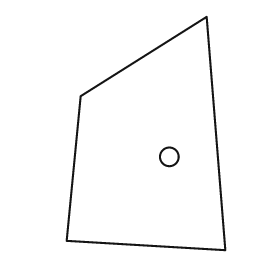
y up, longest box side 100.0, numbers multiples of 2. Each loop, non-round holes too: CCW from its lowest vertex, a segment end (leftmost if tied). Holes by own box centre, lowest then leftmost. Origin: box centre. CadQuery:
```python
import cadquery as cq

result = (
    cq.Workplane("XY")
    .moveTo(34.0, -50.0)
    .lineTo(26.0, 50.0)
    .lineTo(-28.0, 16.0)
    .lineTo(-34.0, -46.0)
    .close()
    .moveTo(10.0, -10.0)
    .circle(4.0)
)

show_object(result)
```